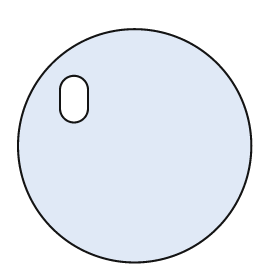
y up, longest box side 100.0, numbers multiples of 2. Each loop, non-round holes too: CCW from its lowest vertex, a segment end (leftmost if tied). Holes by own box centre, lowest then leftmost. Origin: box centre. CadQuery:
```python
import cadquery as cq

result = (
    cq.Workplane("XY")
    .moveTo(0.0, 0.0)
    .circle(50.0)
    .moveTo(-32.0, 16.0)
    .threePointArc((-26.0, 10.0), (-20.0, 16.0))
    .lineTo(-20.0, 24.0)
    .threePointArc((-26.0, 30.0), (-32.0, 24.0))
    .close()
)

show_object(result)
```